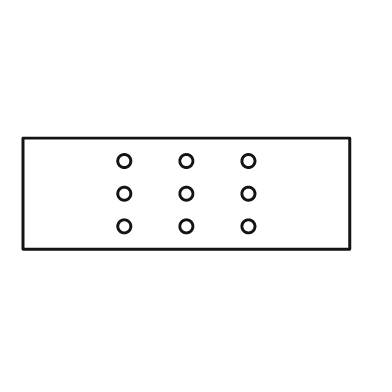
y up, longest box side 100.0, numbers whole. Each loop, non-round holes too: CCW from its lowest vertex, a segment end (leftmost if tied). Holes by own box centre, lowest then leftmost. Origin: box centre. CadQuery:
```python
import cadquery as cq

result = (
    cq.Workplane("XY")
    .moveTo(-50.0, -17.0)
    .lineTo(50.0, -17.0)
    .lineTo(50.0, 17.0)
    .lineTo(-50.0, 17.0)
    .close()
    .moveTo(-19.0, -10.0)
    .circle(2.0)
    .moveTo(0.0, -10.0)
    .circle(2.0)
    .moveTo(19.0, -10.0)
    .circle(2.0)
    .moveTo(-19.0, 0.0)
    .circle(2.0)
    .moveTo(0.0, 0.0)
    .circle(2.0)
    .moveTo(19.0, 0.0)
    .circle(2.0)
    .moveTo(-19.0, 10.0)
    .circle(2.0)
    .moveTo(0.0, 10.0)
    .circle(2.0)
    .moveTo(19.0, 10.0)
    .circle(2.0)
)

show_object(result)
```